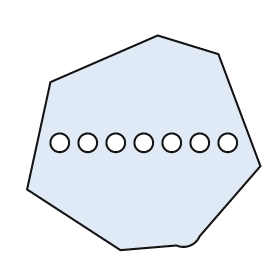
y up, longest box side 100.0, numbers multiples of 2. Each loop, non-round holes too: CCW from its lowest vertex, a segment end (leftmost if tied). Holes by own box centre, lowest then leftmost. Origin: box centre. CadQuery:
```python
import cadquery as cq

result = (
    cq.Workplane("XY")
    .moveTo(-10.0, -46.0)
    .lineTo(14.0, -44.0)
    .threePointArc((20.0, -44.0), (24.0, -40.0))
    .lineTo(50.0, -10.0)
    .lineTo(32.0, 38.0)
    .lineTo(6.0, 46.0)
    .lineTo(-40.0, 26.0)
    .lineTo(-50.0, -20.0)
    .close()
    .moveTo(-36.0, 0.0)
    .circle(4.0)
    .moveTo(-24.0, 0.0)
    .circle(4.0)
    .moveTo(-12.0, 0.0)
    .circle(4.0)
    .moveTo(0.0, 0.0)
    .circle(4.0)
    .moveTo(12.0, 0.0)
    .circle(4.0)
    .moveTo(24.0, 0.0)
    .circle(4.0)
    .moveTo(36.0, 0.0)
    .circle(4.0)
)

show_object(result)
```